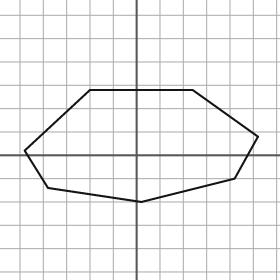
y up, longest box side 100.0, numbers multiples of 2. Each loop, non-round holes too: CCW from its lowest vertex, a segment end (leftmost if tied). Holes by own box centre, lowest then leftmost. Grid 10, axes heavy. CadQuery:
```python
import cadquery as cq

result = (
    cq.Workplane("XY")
    .moveTo(2.0, -20.0)
    .lineTo(42.0, -10.0)
    .lineTo(52.0, 8.0)
    .lineTo(24.0, 28.0)
    .lineTo(-20.0, 28.0)
    .lineTo(-48.0, 2.0)
    .lineTo(-38.0, -14.0)
    .close()
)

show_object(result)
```